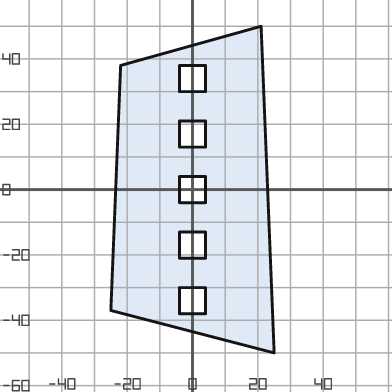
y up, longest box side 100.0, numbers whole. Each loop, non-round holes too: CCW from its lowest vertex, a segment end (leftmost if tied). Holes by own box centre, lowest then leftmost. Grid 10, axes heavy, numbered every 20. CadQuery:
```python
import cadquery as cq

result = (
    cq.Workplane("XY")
    .moveTo(25.0, -50.0)
    .lineTo(21.0, 50.0)
    .lineTo(-22.0, 38.0)
    .lineTo(-25.0, -37.0)
    .close()
    .moveTo(-4.0, -38.0)
    .lineTo(4.0, -38.0)
    .lineTo(4.0, -30.0)
    .lineTo(-4.0, -30.0)
    .close()
    .moveTo(-4.0, -21.0)
    .lineTo(4.0, -21.0)
    .lineTo(4.0, -13.0)
    .lineTo(-4.0, -13.0)
    .close()
    .moveTo(-4.0, -4.0)
    .lineTo(4.0, -4.0)
    .lineTo(4.0, 4.0)
    .lineTo(-4.0, 4.0)
    .close()
    .moveTo(-4.0, 13.0)
    .lineTo(4.0, 13.0)
    .lineTo(4.0, 21.0)
    .lineTo(-4.0, 21.0)
    .close()
    .moveTo(-4.0, 30.0)
    .lineTo(4.0, 30.0)
    .lineTo(4.0, 38.0)
    .lineTo(-4.0, 38.0)
    .close()
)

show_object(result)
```